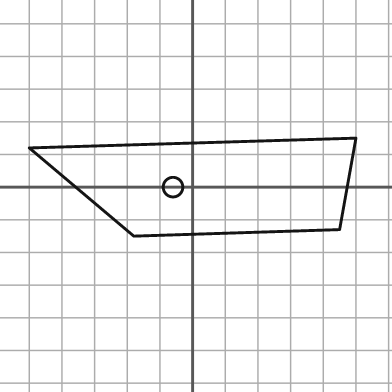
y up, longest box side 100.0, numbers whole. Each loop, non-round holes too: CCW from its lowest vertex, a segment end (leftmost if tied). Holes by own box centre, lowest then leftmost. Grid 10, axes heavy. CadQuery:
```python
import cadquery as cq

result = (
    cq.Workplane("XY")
    .moveTo(-18.0, -15.0)
    .lineTo(45.0, -13.0)
    .lineTo(50.0, 15.0)
    .lineTo(-50.0, 12.0)
    .close()
    .moveTo(-6.0, 0.0)
    .circle(3.0)
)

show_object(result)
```